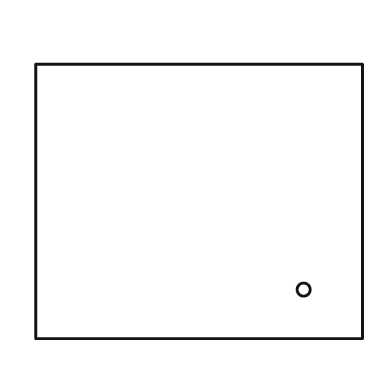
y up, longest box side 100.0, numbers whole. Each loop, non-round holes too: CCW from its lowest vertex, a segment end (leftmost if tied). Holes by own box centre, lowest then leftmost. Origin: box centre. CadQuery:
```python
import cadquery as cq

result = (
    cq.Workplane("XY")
    .moveTo(-50.0, -42.0)
    .lineTo(50.0, -42.0)
    .lineTo(50.0, 42.0)
    .lineTo(-50.0, 42.0)
    .close()
    .moveTo(32.0, -27.0)
    .circle(2.0)
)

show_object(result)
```